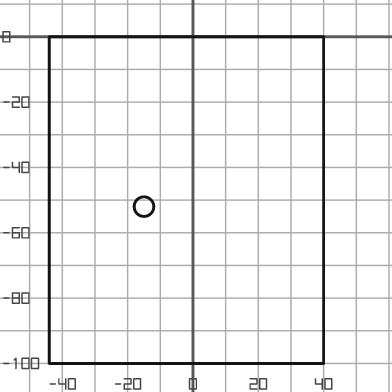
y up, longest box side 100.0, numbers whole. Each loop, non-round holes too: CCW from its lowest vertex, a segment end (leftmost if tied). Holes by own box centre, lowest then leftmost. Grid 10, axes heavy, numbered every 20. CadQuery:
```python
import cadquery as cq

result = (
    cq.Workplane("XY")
    .moveTo(-44.0, -100.0)
    .lineTo(40.0, -100.0)
    .lineTo(40.0, 0.0)
    .lineTo(-44.0, 0.0)
    .close()
    .moveTo(-15.0, -52.0)
    .circle(3.0)
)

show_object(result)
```